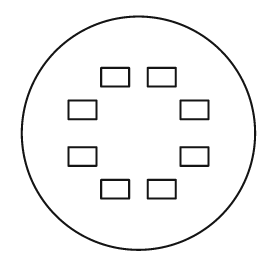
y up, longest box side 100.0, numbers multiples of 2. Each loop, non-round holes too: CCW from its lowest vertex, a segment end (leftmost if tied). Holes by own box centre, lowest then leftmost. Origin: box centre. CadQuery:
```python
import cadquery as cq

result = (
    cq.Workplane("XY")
    .moveTo(0.0, 0.0)
    .circle(50.0)
    .moveTo(-16.0, -28.0)
    .lineTo(-4.0, -28.0)
    .lineTo(-4.0, -20.0)
    .lineTo(-16.0, -20.0)
    .close()
    .moveTo(4.0, -28.0)
    .lineTo(16.0, -28.0)
    .lineTo(16.0, -20.0)
    .lineTo(4.0, -20.0)
    .close()
    .moveTo(-30.0, -14.0)
    .lineTo(-18.0, -14.0)
    .lineTo(-18.0, -6.0)
    .lineTo(-30.0, -6.0)
    .close()
    .moveTo(18.0, -14.0)
    .lineTo(30.0, -14.0)
    .lineTo(30.0, -6.0)
    .lineTo(18.0, -6.0)
    .close()
    .moveTo(-30.0, 6.0)
    .lineTo(-18.0, 6.0)
    .lineTo(-18.0, 14.0)
    .lineTo(-30.0, 14.0)
    .close()
    .moveTo(18.0, 6.0)
    .lineTo(30.0, 6.0)
    .lineTo(30.0, 14.0)
    .lineTo(18.0, 14.0)
    .close()
    .moveTo(-16.0, 20.0)
    .lineTo(-4.0, 20.0)
    .lineTo(-4.0, 28.0)
    .lineTo(-16.0, 28.0)
    .close()
    .moveTo(4.0, 20.0)
    .lineTo(16.0, 20.0)
    .lineTo(16.0, 28.0)
    .lineTo(4.0, 28.0)
    .close()
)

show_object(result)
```